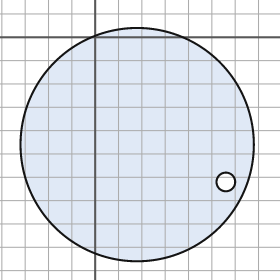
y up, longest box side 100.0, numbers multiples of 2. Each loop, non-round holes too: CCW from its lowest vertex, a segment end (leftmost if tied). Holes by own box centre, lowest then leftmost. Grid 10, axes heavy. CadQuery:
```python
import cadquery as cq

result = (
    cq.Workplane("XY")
    .moveTo(18.0, -46.0)
    .circle(50.0)
    .moveTo(56.0, -62.0)
    .circle(4.0)
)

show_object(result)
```